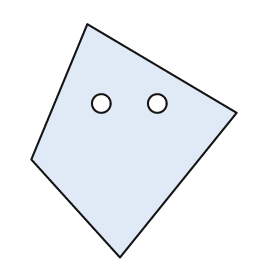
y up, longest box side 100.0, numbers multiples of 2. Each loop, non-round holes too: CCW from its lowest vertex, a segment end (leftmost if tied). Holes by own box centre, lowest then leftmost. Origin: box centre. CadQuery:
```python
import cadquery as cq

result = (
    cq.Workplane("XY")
    .moveTo(-6.0, -50.0)
    .lineTo(44.0, 12.0)
    .lineTo(-20.0, 50.0)
    .lineTo(-44.0, -8.0)
    .close()
    .moveTo(-14.0, 16.0)
    .circle(4.0)
    .moveTo(10.0, 16.0)
    .circle(4.0)
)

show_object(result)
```